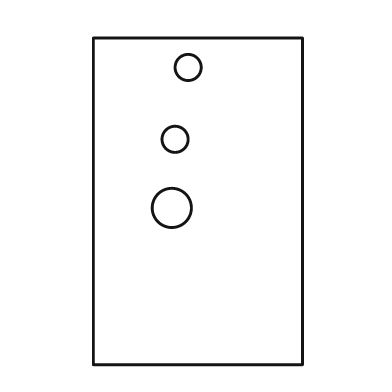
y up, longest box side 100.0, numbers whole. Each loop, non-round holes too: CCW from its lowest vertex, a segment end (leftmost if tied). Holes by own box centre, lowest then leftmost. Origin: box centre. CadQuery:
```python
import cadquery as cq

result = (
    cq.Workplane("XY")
    .moveTo(-32.0, -50.0)
    .lineTo(32.0, -50.0)
    .lineTo(32.0, 50.0)
    .lineTo(-32.0, 50.0)
    .close()
    .moveTo(-8.0, -2.0)
    .circle(6.0)
    .moveTo(-7.0, 19.0)
    .circle(4.0)
    .moveTo(-3.0, 41.0)
    .circle(4.0)
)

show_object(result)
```